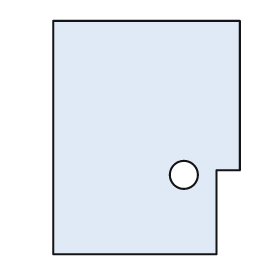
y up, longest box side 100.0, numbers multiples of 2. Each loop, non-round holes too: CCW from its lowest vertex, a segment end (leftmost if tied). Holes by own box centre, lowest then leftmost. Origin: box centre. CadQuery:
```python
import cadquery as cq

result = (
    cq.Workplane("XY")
    .moveTo(-40.0, -50.0)
    .lineTo(30.0, -50.0)
    .lineTo(30.0, -14.0)
    .lineTo(40.0, -14.0)
    .lineTo(40.0, 50.0)
    .lineTo(-40.0, 50.0)
    .close()
    .moveTo(16.0, -16.0)
    .circle(6.0)
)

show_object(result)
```